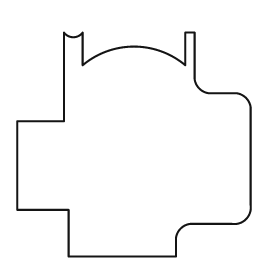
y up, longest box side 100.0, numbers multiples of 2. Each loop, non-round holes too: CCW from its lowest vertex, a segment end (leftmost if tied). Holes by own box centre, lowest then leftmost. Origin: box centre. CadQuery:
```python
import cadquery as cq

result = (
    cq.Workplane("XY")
    .moveTo(-28.0, -48.0)
    .lineTo(18.0, -48.0)
    .lineTo(18.0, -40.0)
    .threePointArc((20.0, -36.0), (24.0, -34.0))
    .lineTo(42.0, -34.0)
    .threePointArc((48.0, -32.0), (50.0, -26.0))
    .lineTo(50.0, 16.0)
    .threePointArc((48.0, 20.0), (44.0, 22.0))
    .lineTo(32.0, 22.0)
    .threePointArc((28.0, 24.0), (26.0, 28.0))
    .lineTo(26.0, 48.0)
    .lineTo(22.0, 48.0)
    .lineTo(22.0, 34.0)
    .threePointArc((0.0, 42.0), (-22.0, 34.0))
    .lineTo(-22.0, 48.0)
    .threePointArc((-26.0, 46.0), (-30.0, 48.0))
    .lineTo(-30.0, 10.0)
    .lineTo(-50.0, 10.0)
    .lineTo(-50.0, -28.0)
    .lineTo(-28.0, -28.0)
    .close()
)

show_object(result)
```